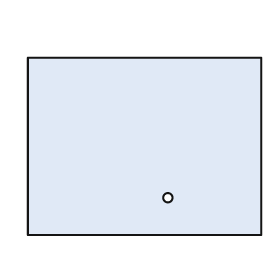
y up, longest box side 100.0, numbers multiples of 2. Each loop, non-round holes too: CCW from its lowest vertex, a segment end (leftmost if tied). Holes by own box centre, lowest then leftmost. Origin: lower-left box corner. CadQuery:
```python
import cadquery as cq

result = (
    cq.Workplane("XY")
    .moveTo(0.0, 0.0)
    .lineTo(100.0, 0.0)
    .lineTo(100.0, 76.0)
    .lineTo(0.0, 76.0)
    .close()
    .moveTo(60.0, 16.0)
    .circle(2.0)
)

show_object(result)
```